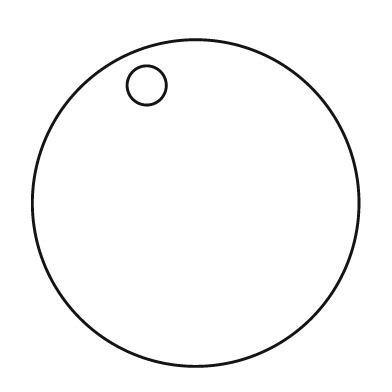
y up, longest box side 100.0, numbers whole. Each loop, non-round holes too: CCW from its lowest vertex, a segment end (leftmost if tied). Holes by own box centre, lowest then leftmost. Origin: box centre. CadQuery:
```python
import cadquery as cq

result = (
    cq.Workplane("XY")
    .moveTo(0.0, 0.0)
    .circle(50.0)
    .moveTo(-15.0, 36.0)
    .circle(6.0)
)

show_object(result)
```